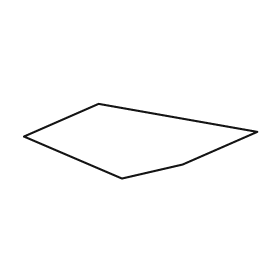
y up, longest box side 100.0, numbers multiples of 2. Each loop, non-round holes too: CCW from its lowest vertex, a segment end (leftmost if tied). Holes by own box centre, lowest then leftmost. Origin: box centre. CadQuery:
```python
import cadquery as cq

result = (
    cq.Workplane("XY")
    .moveTo(-8.0, -16.0)
    .lineTo(18.0, -10.0)
    .lineTo(50.0, 4.0)
    .lineTo(-18.0, 16.0)
    .lineTo(-50.0, 2.0)
    .close()
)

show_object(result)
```